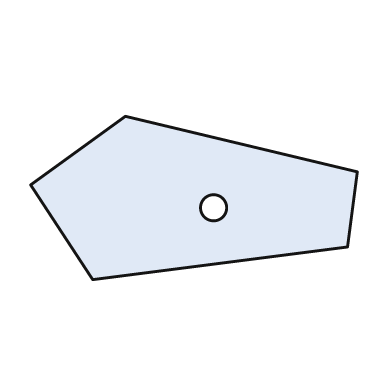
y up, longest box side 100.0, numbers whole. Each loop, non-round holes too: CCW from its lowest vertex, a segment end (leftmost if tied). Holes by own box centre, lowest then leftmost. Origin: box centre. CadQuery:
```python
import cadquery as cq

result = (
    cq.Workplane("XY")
    .moveTo(-31.0, -25.0)
    .lineTo(47.0, -15.0)
    .lineTo(50.0, 8.0)
    .lineTo(-21.0, 25.0)
    .lineTo(-50.0, 4.0)
    .close()
    .moveTo(6.0, -3.0)
    .circle(4.0)
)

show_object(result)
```